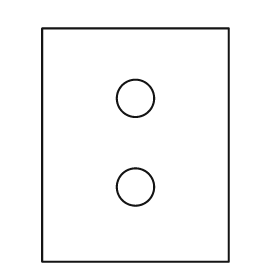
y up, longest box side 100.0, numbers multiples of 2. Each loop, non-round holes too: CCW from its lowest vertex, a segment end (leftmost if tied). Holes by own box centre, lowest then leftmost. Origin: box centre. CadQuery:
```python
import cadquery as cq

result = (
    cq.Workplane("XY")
    .moveTo(-40.0, -50.0)
    .lineTo(40.0, -50.0)
    .lineTo(40.0, 50.0)
    .lineTo(-40.0, 50.0)
    .close()
    .moveTo(0.0, -18.0)
    .circle(8.0)
    .moveTo(0.0, 20.0)
    .circle(8.0)
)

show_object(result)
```